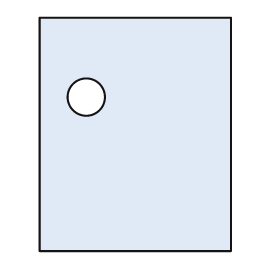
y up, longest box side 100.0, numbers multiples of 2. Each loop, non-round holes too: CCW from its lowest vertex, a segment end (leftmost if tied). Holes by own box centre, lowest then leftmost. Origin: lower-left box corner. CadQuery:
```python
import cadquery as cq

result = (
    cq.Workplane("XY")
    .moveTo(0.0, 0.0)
    .lineTo(82.0, 0.0)
    .lineTo(82.0, 100.0)
    .lineTo(0.0, 100.0)
    .close()
    .moveTo(20.0, 66.0)
    .circle(8.0)
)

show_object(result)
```